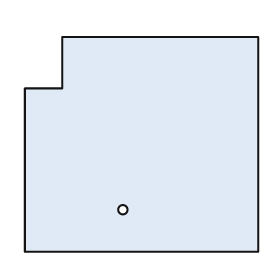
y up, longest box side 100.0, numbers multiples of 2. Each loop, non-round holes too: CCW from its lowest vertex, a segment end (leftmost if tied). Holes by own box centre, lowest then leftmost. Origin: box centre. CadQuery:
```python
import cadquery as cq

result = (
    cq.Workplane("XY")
    .moveTo(-50.0, -46.0)
    .lineTo(50.0, -46.0)
    .lineTo(50.0, 46.0)
    .lineTo(-34.0, 46.0)
    .lineTo(-34.0, 24.0)
    .lineTo(-50.0, 24.0)
    .close()
    .moveTo(-8.0, -28.0)
    .circle(2.0)
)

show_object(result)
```